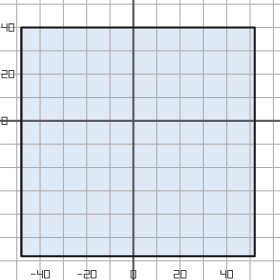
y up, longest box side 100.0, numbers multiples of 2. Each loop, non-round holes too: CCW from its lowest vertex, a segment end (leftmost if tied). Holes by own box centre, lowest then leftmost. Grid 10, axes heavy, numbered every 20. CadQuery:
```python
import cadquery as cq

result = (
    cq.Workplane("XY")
    .moveTo(-48.0, -58.0)
    .lineTo(52.0, -58.0)
    .lineTo(52.0, 40.0)
    .lineTo(-48.0, 40.0)
    .close()
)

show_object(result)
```